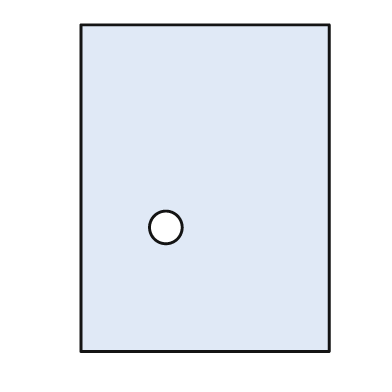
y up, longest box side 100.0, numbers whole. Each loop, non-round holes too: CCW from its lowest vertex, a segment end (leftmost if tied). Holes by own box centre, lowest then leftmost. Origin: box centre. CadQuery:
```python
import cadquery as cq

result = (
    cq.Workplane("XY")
    .moveTo(-38.0, -50.0)
    .lineTo(38.0, -50.0)
    .lineTo(38.0, 50.0)
    .lineTo(-38.0, 50.0)
    .close()
    .moveTo(-12.0, -12.0)
    .circle(5.0)
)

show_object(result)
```